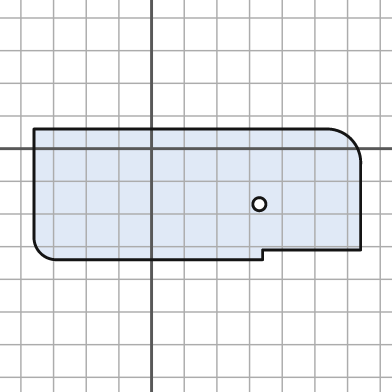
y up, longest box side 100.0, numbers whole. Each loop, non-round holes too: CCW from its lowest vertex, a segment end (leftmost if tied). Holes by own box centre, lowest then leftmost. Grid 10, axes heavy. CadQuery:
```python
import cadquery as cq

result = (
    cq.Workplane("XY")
    .moveTo(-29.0, -34.0)
    .lineTo(34.0, -34.0)
    .lineTo(34.0, -31.0)
    .lineTo(64.0, -31.0)
    .lineTo(64.0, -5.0)
    .threePointArc((61.0, 3.0), (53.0, 6.0))
    .lineTo(-36.0, 6.0)
    .lineTo(-36.0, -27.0)
    .threePointArc((-34.0, -32.0), (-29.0, -34.0))
    .close()
    .moveTo(33.0, -17.0)
    .circle(2.0)
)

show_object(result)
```